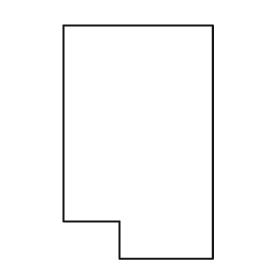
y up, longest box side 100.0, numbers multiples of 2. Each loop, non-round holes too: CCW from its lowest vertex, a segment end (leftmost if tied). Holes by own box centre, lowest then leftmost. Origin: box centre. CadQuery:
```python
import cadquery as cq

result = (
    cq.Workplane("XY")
    .moveTo(-8.0, -50.0)
    .lineTo(32.0, -50.0)
    .lineTo(32.0, 50.0)
    .lineTo(-32.0, 50.0)
    .lineTo(-32.0, -34.0)
    .lineTo(-8.0, -34.0)
    .close()
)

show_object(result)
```